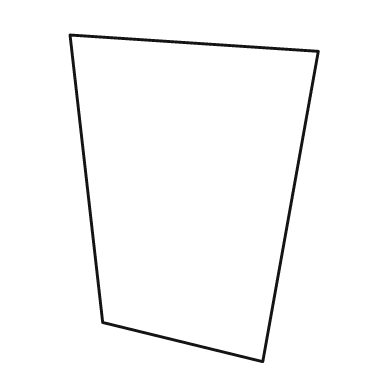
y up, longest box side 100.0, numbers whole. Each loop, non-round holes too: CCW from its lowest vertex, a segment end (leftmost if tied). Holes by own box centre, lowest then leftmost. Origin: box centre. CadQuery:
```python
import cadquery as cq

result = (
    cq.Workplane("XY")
    .moveTo(21.0, -50.0)
    .lineTo(38.0, 45.0)
    .lineTo(-38.0, 50.0)
    .lineTo(-28.0, -38.0)
    .close()
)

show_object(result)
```